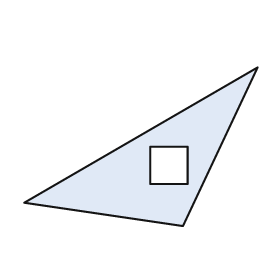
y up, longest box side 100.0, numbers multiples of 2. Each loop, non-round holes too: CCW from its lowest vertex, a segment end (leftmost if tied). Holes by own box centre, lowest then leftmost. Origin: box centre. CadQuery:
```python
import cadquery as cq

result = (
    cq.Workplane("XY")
    .moveTo(18.0, -34.0)
    .lineTo(50.0, 34.0)
    .lineTo(-50.0, -24.0)
    .close()
    .moveTo(4.0, -16.0)
    .lineTo(20.0, -16.0)
    .lineTo(20.0, 0.0)
    .lineTo(4.0, 0.0)
    .close()
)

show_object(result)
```